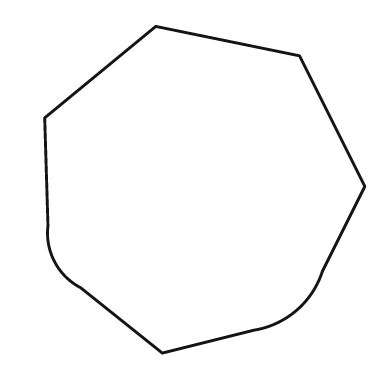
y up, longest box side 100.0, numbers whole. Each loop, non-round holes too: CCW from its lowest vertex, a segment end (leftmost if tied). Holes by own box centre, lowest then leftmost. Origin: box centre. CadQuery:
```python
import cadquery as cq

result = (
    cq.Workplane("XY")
    .moveTo(-13.0, -50.0)
    .lineTo(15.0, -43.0)
    .threePointArc((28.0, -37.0), (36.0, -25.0))
    .lineTo(49.0, 1.0)
    .lineTo(29.0, 41.0)
    .lineTo(-15.0, 50.0)
    .lineTo(-49.0, 22.0)
    .lineTo(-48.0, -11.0)
    .threePointArc((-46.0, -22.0), (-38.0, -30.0))
    .close()
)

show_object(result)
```